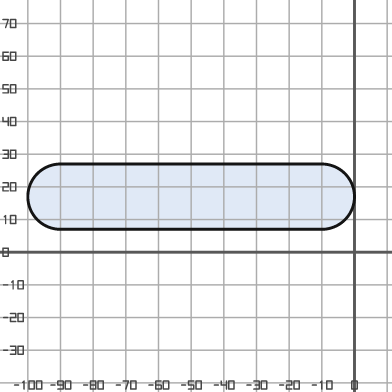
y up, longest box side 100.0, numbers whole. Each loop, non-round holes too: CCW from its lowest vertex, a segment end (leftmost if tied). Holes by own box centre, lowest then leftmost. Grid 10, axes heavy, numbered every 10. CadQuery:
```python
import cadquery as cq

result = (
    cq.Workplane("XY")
    .moveTo(-90.0, 7.0)
    .lineTo(-10.0, 7.0)
    .threePointArc((0.0, 17.0), (-10.0, 27.0))
    .lineTo(-90.0, 27.0)
    .threePointArc((-100.0, 17.0), (-90.0, 7.0))
    .close()
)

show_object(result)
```